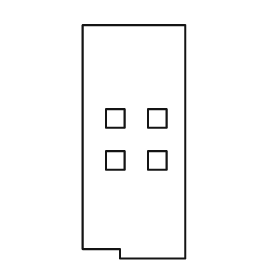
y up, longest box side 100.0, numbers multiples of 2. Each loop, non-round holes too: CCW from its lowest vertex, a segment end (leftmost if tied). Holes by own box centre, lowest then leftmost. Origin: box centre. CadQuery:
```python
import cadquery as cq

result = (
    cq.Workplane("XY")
    .moveTo(-6.0, -50.0)
    .lineTo(22.0, -50.0)
    .lineTo(22.0, 50.0)
    .lineTo(-22.0, 50.0)
    .lineTo(-22.0, -46.0)
    .lineTo(-6.0, -46.0)
    .close()
    .moveTo(-12.0, -12.0)
    .lineTo(-4.0, -12.0)
    .lineTo(-4.0, -4.0)
    .lineTo(-12.0, -4.0)
    .close()
    .moveTo(6.0, -12.0)
    .lineTo(14.0, -12.0)
    .lineTo(14.0, -4.0)
    .lineTo(6.0, -4.0)
    .close()
    .moveTo(-12.0, 6.0)
    .lineTo(-4.0, 6.0)
    .lineTo(-4.0, 14.0)
    .lineTo(-12.0, 14.0)
    .close()
    .moveTo(6.0, 6.0)
    .lineTo(14.0, 6.0)
    .lineTo(14.0, 14.0)
    .lineTo(6.0, 14.0)
    .close()
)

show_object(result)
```